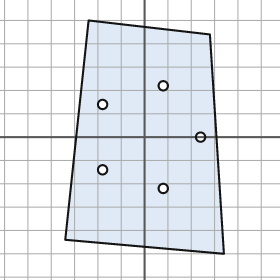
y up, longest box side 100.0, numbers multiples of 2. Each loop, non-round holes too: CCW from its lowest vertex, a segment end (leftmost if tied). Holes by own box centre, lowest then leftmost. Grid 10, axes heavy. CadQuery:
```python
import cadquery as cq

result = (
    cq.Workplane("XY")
    .moveTo(34.0, -50.0)
    .lineTo(28.0, 44.0)
    .lineTo(-24.0, 50.0)
    .lineTo(-34.0, -44.0)
    .close()
    .moveTo(8.0, -22.0)
    .circle(2.0)
    .moveTo(-18.0, -14.0)
    .circle(2.0)
    .moveTo(24.0, 0.0)
    .circle(2.0)
    .moveTo(-18.0, 14.0)
    .circle(2.0)
    .moveTo(8.0, 22.0)
    .circle(2.0)
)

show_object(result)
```